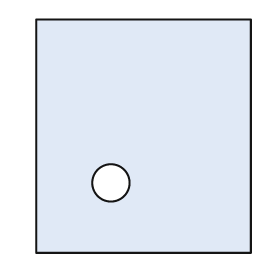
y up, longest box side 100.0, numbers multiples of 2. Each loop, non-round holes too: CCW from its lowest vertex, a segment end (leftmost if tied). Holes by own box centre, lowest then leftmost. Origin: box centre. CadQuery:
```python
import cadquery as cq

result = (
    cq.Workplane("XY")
    .moveTo(-46.0, -50.0)
    .lineTo(46.0, -50.0)
    .lineTo(46.0, 50.0)
    .lineTo(-46.0, 50.0)
    .close()
    .moveTo(-14.0, -20.0)
    .circle(8.0)
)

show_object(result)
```